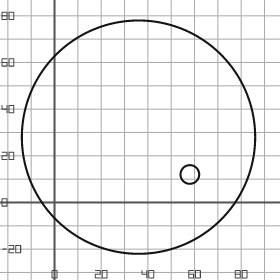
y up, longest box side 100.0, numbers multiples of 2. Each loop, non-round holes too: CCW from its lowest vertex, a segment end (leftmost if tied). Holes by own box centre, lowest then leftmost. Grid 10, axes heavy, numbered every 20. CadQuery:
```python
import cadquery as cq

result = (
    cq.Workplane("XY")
    .moveTo(36.0, 28.0)
    .circle(50.0)
    .moveTo(58.0, 12.0)
    .circle(4.0)
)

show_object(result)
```